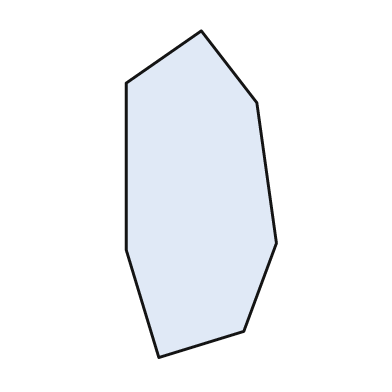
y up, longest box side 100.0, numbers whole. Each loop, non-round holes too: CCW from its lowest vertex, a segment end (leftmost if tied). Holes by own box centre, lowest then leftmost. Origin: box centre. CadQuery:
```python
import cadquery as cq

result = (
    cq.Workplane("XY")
    .moveTo(-13.0, -50.0)
    .lineTo(13.0, -42.0)
    .lineTo(23.0, -15.0)
    .lineTo(17.0, 28.0)
    .lineTo(0.0, 50.0)
    .lineTo(-23.0, 34.0)
    .lineTo(-23.0, -17.0)
    .close()
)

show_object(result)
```